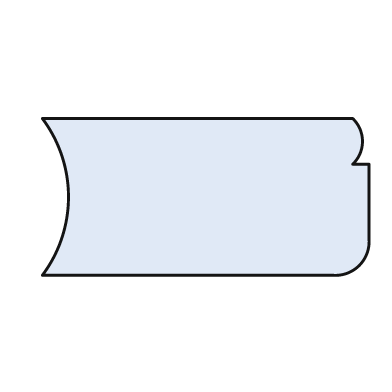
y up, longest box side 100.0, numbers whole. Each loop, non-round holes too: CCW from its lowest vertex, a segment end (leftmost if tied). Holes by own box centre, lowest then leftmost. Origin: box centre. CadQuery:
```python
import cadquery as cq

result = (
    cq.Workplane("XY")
    .moveTo(-50.0, -24.0)
    .lineTo(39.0, -24.0)
    .threePointArc((47.0, -21.0), (50.0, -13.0))
    .lineTo(50.0, 10.0)
    .lineTo(45.0, 10.0)
    .threePointArc((48.0, 17.0), (45.0, 24.0))
    .lineTo(-50.0, 24.0)
    .threePointArc((-42.0, 0.0), (-50.0, -24.0))
    .close()
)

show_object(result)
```